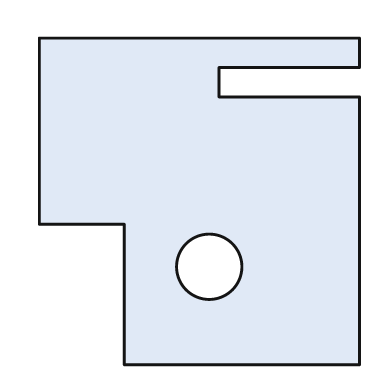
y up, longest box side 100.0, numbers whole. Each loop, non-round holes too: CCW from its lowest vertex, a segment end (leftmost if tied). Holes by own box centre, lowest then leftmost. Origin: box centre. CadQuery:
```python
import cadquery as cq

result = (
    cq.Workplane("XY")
    .moveTo(-23.0, -50.0)
    .lineTo(49.0, -50.0)
    .lineTo(49.0, 32.0)
    .lineTo(6.0, 32.0)
    .lineTo(6.0, 41.0)
    .lineTo(49.0, 41.0)
    .lineTo(49.0, 50.0)
    .lineTo(-49.0, 50.0)
    .lineTo(-49.0, -7.0)
    .lineTo(-23.0, -7.0)
    .close()
    .moveTo(3.0, -20.0)
    .circle(10.0)
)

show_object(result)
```